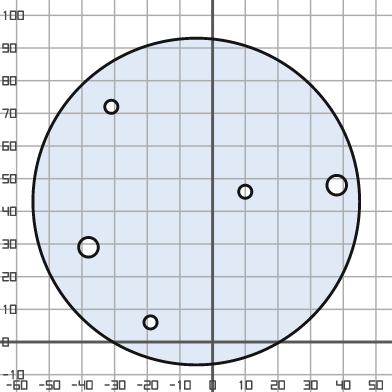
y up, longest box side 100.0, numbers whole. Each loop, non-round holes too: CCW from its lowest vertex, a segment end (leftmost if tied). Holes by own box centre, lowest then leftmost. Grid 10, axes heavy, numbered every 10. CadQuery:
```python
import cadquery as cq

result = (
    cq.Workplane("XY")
    .moveTo(-5.0, 43.0)
    .circle(50.0)
    .moveTo(-19.0, 6.0)
    .circle(2.0)
    .moveTo(-38.0, 29.0)
    .circle(3.0)
    .moveTo(10.0, 46.0)
    .circle(2.0)
    .moveTo(38.0, 48.0)
    .circle(3.0)
    .moveTo(-31.0, 72.0)
    .circle(2.0)
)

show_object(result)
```